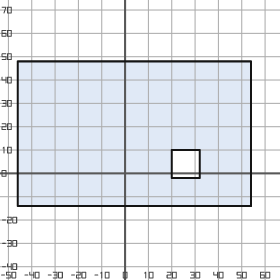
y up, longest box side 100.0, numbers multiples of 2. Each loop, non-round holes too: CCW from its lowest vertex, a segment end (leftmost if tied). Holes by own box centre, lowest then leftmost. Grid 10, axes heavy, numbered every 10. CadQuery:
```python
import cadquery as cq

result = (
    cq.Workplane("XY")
    .moveTo(-46.0, -14.0)
    .lineTo(54.0, -14.0)
    .lineTo(54.0, 48.0)
    .lineTo(-46.0, 48.0)
    .close()
    .moveTo(20.0, -2.0)
    .lineTo(32.0, -2.0)
    .lineTo(32.0, 10.0)
    .lineTo(20.0, 10.0)
    .close()
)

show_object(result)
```